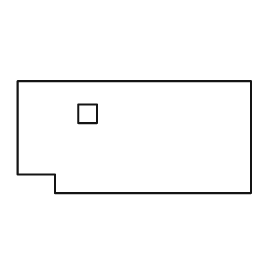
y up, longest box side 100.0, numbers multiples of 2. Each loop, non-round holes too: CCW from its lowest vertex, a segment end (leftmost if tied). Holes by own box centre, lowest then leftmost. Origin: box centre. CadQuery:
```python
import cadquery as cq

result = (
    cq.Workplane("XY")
    .moveTo(-34.0, -24.0)
    .lineTo(50.0, -24.0)
    .lineTo(50.0, 24.0)
    .lineTo(-50.0, 24.0)
    .lineTo(-50.0, -16.0)
    .lineTo(-34.0, -16.0)
    .close()
    .moveTo(-24.0, 6.0)
    .lineTo(-16.0, 6.0)
    .lineTo(-16.0, 14.0)
    .lineTo(-24.0, 14.0)
    .close()
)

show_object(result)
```